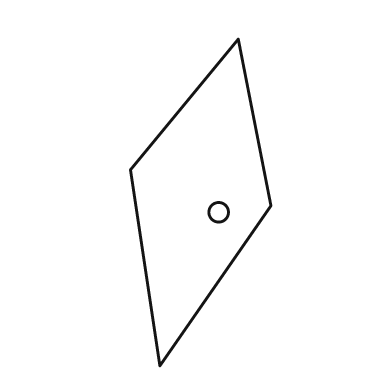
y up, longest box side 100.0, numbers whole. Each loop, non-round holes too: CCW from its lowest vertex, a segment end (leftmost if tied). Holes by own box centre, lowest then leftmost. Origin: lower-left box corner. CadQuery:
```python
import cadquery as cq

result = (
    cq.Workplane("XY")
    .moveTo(9.0, 0.0)
    .lineTo(43.0, 49.0)
    .lineTo(33.0, 100.0)
    .lineTo(0.0, 60.0)
    .close()
    .moveTo(27.0, 47.0)
    .circle(3.0)
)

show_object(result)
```